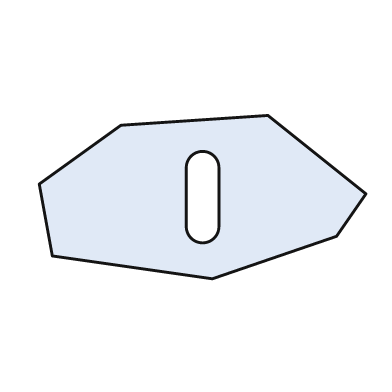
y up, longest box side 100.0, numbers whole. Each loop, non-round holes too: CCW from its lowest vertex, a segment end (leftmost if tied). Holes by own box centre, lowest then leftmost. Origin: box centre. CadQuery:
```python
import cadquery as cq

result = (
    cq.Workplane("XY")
    .moveTo(3.0, -25.0)
    .lineTo(41.0, -12.0)
    .lineTo(50.0, 1.0)
    .lineTo(20.0, 25.0)
    .lineTo(-25.0, 22.0)
    .lineTo(-50.0, 4.0)
    .lineTo(-46.0, -18.0)
    .close()
    .moveTo(-5.0, -9.0)
    .threePointArc((0.0, -14.0), (5.0, -9.0))
    .lineTo(5.0, 9.0)
    .threePointArc((0.0, 14.0), (-5.0, 9.0))
    .close()
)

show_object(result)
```